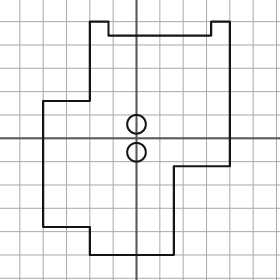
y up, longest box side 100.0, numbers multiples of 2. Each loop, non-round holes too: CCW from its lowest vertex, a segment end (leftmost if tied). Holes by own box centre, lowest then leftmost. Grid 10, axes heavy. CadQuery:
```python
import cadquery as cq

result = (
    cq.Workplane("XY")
    .moveTo(-20.0, -50.0)
    .lineTo(16.0, -50.0)
    .lineTo(16.0, -12.0)
    .lineTo(40.0, -12.0)
    .lineTo(40.0, 50.0)
    .lineTo(32.0, 50.0)
    .lineTo(32.0, 44.0)
    .lineTo(-12.0, 44.0)
    .lineTo(-12.0, 50.0)
    .lineTo(-20.0, 50.0)
    .lineTo(-20.0, 16.0)
    .lineTo(-40.0, 16.0)
    .lineTo(-40.0, -38.0)
    .lineTo(-20.0, -38.0)
    .close()
    .moveTo(0.0, -6.0)
    .circle(4.0)
    .moveTo(0.0, 6.0)
    .circle(4.0)
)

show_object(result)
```